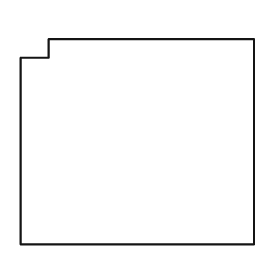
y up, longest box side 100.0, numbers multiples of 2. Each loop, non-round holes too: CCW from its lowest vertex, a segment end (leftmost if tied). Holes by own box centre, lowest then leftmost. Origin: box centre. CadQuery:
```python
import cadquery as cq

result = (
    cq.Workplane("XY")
    .moveTo(-50.0, -44.0)
    .lineTo(50.0, -44.0)
    .lineTo(50.0, 44.0)
    .lineTo(-38.0, 44.0)
    .lineTo(-38.0, 36.0)
    .lineTo(-50.0, 36.0)
    .close()
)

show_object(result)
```